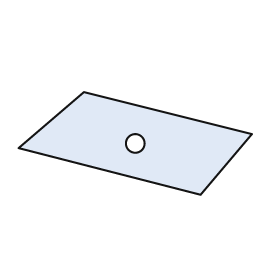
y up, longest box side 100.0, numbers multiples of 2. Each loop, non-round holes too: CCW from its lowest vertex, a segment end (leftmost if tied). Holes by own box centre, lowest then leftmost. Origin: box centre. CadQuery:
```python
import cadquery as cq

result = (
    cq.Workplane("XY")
    .moveTo(28.0, -22.0)
    .lineTo(50.0, 4.0)
    .lineTo(-22.0, 22.0)
    .lineTo(-50.0, -2.0)
    .close()
    .moveTo(0.0, 0.0)
    .circle(4.0)
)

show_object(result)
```